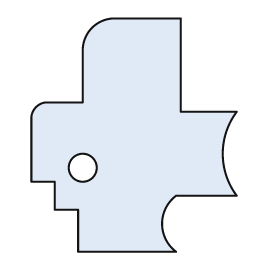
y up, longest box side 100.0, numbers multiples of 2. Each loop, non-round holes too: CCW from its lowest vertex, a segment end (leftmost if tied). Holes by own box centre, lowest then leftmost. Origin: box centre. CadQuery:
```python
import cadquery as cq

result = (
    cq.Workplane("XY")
    .moveTo(-24.0, -50.0)
    .lineTo(18.0, -50.0)
    .threePointArc((12.0, -38.0), (18.0, -26.0))
    .lineTo(44.0, -26.0)
    .threePointArc((38.0, -8.0), (44.0, 10.0))
    .lineTo(20.0, 10.0)
    .lineTo(20.0, 50.0)
    .lineTo(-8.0, 50.0)
    .threePointArc((-18.0, 46.0), (-22.0, 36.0))
    .lineTo(-22.0, 14.0)
    .lineTo(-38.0, 14.0)
    .threePointArc((-42.0, 12.0), (-44.0, 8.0))
    .lineTo(-44.0, -20.0)
    .lineTo(-34.0, -20.0)
    .lineTo(-34.0, -32.0)
    .lineTo(-24.0, -32.0)
    .close()
    .moveTo(-22.0, -14.0)
    .circle(6.0)
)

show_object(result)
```